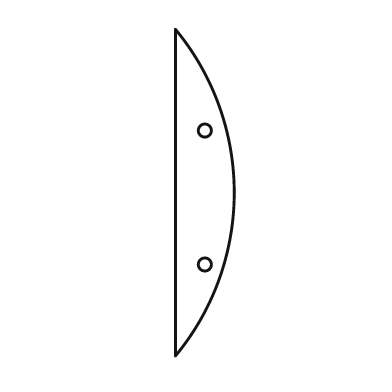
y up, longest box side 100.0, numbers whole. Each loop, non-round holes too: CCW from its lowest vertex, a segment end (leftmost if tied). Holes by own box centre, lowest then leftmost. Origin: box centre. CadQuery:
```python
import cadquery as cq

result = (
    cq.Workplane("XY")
    .moveTo(-9.0, -50.0)
    .threePointArc((9.0, 0.0), (-9.0, 50.0))
    .close()
    .moveTo(0.0, -22.0)
    .circle(2.0)
    .moveTo(0.0, 19.0)
    .circle(2.0)
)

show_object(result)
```